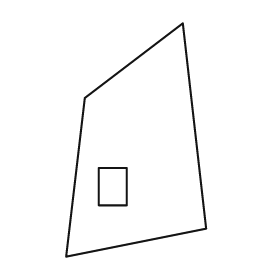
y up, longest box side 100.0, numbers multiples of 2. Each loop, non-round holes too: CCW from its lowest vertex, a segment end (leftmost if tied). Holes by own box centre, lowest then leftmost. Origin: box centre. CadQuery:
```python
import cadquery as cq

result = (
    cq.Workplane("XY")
    .moveTo(-30.0, -50.0)
    .lineTo(30.0, -38.0)
    .lineTo(20.0, 50.0)
    .lineTo(-22.0, 18.0)
    .close()
    .moveTo(-16.0, -28.0)
    .lineTo(-4.0, -28.0)
    .lineTo(-4.0, -12.0)
    .lineTo(-16.0, -12.0)
    .close()
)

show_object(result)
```